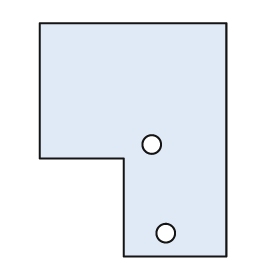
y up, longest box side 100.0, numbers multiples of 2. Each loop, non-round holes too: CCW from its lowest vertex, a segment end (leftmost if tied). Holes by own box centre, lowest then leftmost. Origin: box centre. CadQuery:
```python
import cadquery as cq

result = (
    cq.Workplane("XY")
    .moveTo(-4.0, -50.0)
    .lineTo(40.0, -50.0)
    .lineTo(40.0, 50.0)
    .lineTo(-40.0, 50.0)
    .lineTo(-40.0, -8.0)
    .lineTo(-4.0, -8.0)
    .close()
    .moveTo(14.0, -40.0)
    .circle(4.0)
    .moveTo(8.0, -2.0)
    .circle(4.0)
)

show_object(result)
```